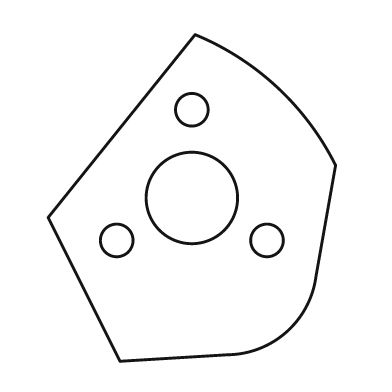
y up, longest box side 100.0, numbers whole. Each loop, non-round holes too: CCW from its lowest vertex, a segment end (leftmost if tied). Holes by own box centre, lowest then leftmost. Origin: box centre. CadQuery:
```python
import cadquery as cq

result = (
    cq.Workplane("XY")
    .moveTo(-22.0, -50.0)
    .lineTo(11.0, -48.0)
    .threePointArc((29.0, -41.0), (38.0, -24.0))
    .lineTo(44.0, 10.0)
    .threePointArc((26.0, 34.0), (1.0, 50.0))
    .lineTo(-44.0, -6.0)
    .close()
    .moveTo(-23.0, -13.0)
    .circle(5.0)
    .moveTo(23.0, -13.0)
    .circle(5.0)
    .moveTo(0.0, 0.0)
    .circle(14.0)
    .moveTo(0.0, 27.0)
    .circle(5.0)
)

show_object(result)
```